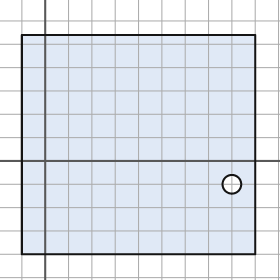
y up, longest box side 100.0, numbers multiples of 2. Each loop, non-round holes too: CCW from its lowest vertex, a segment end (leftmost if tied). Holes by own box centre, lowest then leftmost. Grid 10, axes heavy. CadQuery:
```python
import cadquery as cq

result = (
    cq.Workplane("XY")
    .moveTo(-10.0, -40.0)
    .lineTo(90.0, -40.0)
    .lineTo(90.0, 54.0)
    .lineTo(-10.0, 54.0)
    .close()
    .moveTo(80.0, -10.0)
    .circle(4.0)
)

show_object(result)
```